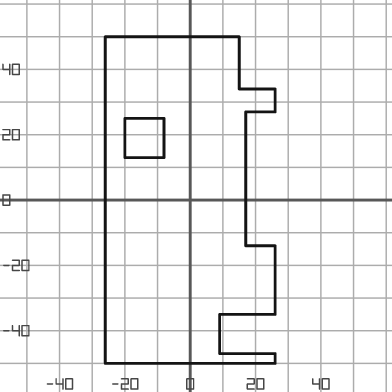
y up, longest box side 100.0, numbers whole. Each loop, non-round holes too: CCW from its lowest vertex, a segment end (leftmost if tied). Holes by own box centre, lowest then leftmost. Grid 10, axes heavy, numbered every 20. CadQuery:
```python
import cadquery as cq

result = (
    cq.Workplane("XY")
    .moveTo(-26.0, -50.0)
    .lineTo(26.0, -50.0)
    .lineTo(26.0, -47.0)
    .lineTo(9.0, -47.0)
    .lineTo(9.0, -35.0)
    .lineTo(26.0, -35.0)
    .lineTo(26.0, -14.0)
    .lineTo(17.0, -14.0)
    .lineTo(17.0, 27.0)
    .lineTo(26.0, 27.0)
    .lineTo(26.0, 34.0)
    .lineTo(15.0, 34.0)
    .lineTo(15.0, 50.0)
    .lineTo(-26.0, 50.0)
    .close()
    .moveTo(-20.0, 13.0)
    .lineTo(-8.0, 13.0)
    .lineTo(-8.0, 25.0)
    .lineTo(-20.0, 25.0)
    .close()
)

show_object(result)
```